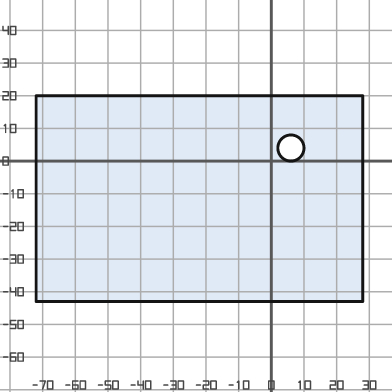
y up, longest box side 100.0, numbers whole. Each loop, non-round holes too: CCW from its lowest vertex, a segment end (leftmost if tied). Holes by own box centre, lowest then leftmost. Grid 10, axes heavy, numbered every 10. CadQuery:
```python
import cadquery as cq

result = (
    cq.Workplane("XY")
    .moveTo(-72.0, -43.0)
    .lineTo(28.0, -43.0)
    .lineTo(28.0, 20.0)
    .lineTo(-72.0, 20.0)
    .close()
    .moveTo(6.0, 4.0)
    .circle(4.0)
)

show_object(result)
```